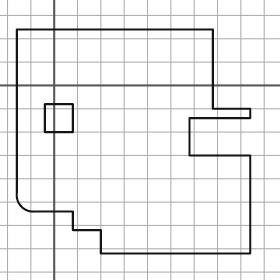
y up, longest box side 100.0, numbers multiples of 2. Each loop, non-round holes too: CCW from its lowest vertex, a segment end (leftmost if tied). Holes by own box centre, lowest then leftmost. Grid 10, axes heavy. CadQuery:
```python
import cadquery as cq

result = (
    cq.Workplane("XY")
    .moveTo(20.0, -72.0)
    .lineTo(84.0, -72.0)
    .lineTo(84.0, -30.0)
    .lineTo(58.0, -30.0)
    .lineTo(58.0, -14.0)
    .lineTo(84.0, -14.0)
    .lineTo(84.0, -10.0)
    .lineTo(68.0, -10.0)
    .lineTo(68.0, 24.0)
    .lineTo(-16.0, 24.0)
    .lineTo(-16.0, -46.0)
    .threePointArc((-14.0, -52.0), (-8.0, -54.0))
    .lineTo(8.0, -54.0)
    .lineTo(8.0, -62.0)
    .lineTo(20.0, -62.0)
    .close()
    .moveTo(-4.0, -20.0)
    .lineTo(8.0, -20.0)
    .lineTo(8.0, -8.0)
    .lineTo(-4.0, -8.0)
    .close()
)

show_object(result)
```